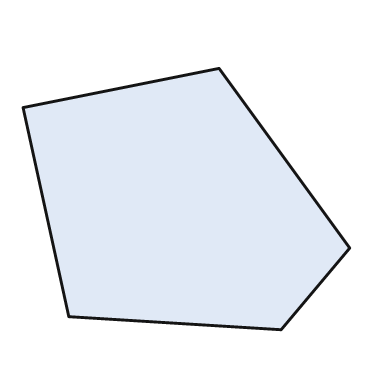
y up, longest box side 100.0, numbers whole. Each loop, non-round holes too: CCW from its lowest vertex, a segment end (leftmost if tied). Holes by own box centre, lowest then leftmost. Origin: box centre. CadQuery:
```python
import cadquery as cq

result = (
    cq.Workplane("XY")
    .moveTo(29.0, -40.0)
    .lineTo(50.0, -15.0)
    .lineTo(10.0, 40.0)
    .lineTo(-50.0, 28.0)
    .lineTo(-36.0, -36.0)
    .close()
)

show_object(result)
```